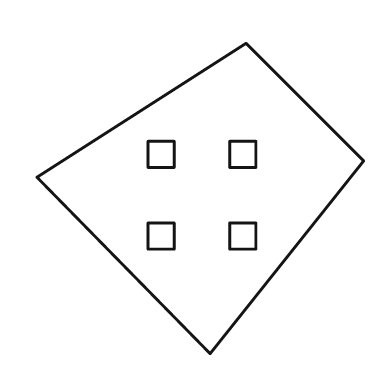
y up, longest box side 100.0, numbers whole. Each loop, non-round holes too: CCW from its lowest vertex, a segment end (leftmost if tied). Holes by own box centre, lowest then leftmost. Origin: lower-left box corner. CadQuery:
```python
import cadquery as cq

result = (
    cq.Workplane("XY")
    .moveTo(53.0, 0.0)
    .lineTo(100.0, 59.0)
    .lineTo(64.0, 95.0)
    .lineTo(0.0, 54.0)
    .close()
    .moveTo(34.0, 32.0)
    .lineTo(42.0, 32.0)
    .lineTo(42.0, 40.0)
    .lineTo(34.0, 40.0)
    .close()
    .moveTo(59.0, 32.0)
    .lineTo(67.0, 32.0)
    .lineTo(67.0, 40.0)
    .lineTo(59.0, 40.0)
    .close()
    .moveTo(34.0, 57.0)
    .lineTo(42.0, 57.0)
    .lineTo(42.0, 65.0)
    .lineTo(34.0, 65.0)
    .close()
    .moveTo(59.0, 57.0)
    .lineTo(67.0, 57.0)
    .lineTo(67.0, 65.0)
    .lineTo(59.0, 65.0)
    .close()
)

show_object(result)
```